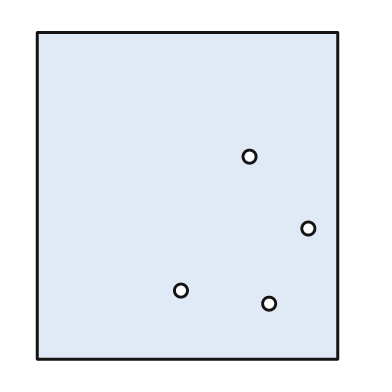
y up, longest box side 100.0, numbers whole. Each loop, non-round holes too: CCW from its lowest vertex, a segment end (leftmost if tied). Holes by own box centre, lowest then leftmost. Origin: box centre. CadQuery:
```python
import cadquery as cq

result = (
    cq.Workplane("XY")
    .moveTo(-46.0, -50.0)
    .lineTo(46.0, -50.0)
    .lineTo(46.0, 50.0)
    .lineTo(-46.0, 50.0)
    .close()
    .moveTo(25.0, -33.0)
    .circle(2.0)
    .moveTo(-2.0, -29.0)
    .circle(2.0)
    .moveTo(37.0, -10.0)
    .circle(2.0)
    .moveTo(19.0, 12.0)
    .circle(2.0)
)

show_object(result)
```